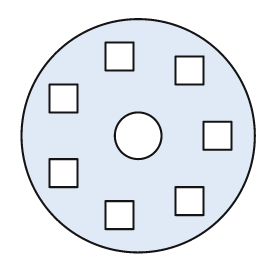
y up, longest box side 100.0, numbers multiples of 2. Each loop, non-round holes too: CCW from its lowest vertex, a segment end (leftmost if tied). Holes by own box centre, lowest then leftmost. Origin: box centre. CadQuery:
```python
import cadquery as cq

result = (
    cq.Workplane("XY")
    .moveTo(0.0, 0.0)
    .circle(50.0)
    .moveTo(-14.0, -40.0)
    .lineTo(-2.0, -40.0)
    .lineTo(-2.0, -28.0)
    .lineTo(-14.0, -28.0)
    .close()
    .moveTo(16.0, -34.0)
    .lineTo(28.0, -34.0)
    .lineTo(28.0, -22.0)
    .lineTo(16.0, -22.0)
    .close()
    .moveTo(-38.0, -22.0)
    .lineTo(-26.0, -22.0)
    .lineTo(-26.0, -10.0)
    .lineTo(-38.0, -10.0)
    .close()
    .moveTo(0.0, 0.0)
    .circle(10.0)
    .moveTo(28.0, -6.0)
    .lineTo(40.0, -6.0)
    .lineTo(40.0, 6.0)
    .lineTo(28.0, 6.0)
    .close()
    .moveTo(-38.0, 10.0)
    .lineTo(-26.0, 10.0)
    .lineTo(-26.0, 22.0)
    .lineTo(-38.0, 22.0)
    .close()
    .moveTo(16.0, 22.0)
    .lineTo(28.0, 22.0)
    .lineTo(28.0, 34.0)
    .lineTo(16.0, 34.0)
    .close()
    .moveTo(-14.0, 28.0)
    .lineTo(-2.0, 28.0)
    .lineTo(-2.0, 40.0)
    .lineTo(-14.0, 40.0)
    .close()
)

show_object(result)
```